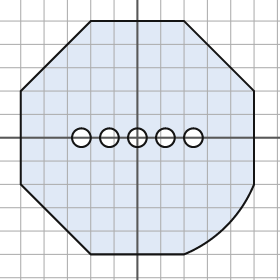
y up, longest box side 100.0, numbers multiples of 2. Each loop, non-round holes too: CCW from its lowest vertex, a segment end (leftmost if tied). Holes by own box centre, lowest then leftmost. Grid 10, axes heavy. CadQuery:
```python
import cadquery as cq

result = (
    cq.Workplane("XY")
    .moveTo(-20.0, -50.0)
    .lineTo(20.0, -50.0)
    .threePointArc((38.0, -38.0), (50.0, -20.0))
    .lineTo(50.0, 20.0)
    .lineTo(20.0, 50.0)
    .lineTo(-20.0, 50.0)
    .lineTo(-50.0, 20.0)
    .lineTo(-50.0, -20.0)
    .close()
    .moveTo(-24.0, 0.0)
    .circle(4.0)
    .moveTo(-12.0, 0.0)
    .circle(4.0)
    .moveTo(0.0, 0.0)
    .circle(4.0)
    .moveTo(12.0, 0.0)
    .circle(4.0)
    .moveTo(24.0, 0.0)
    .circle(4.0)
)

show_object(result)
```